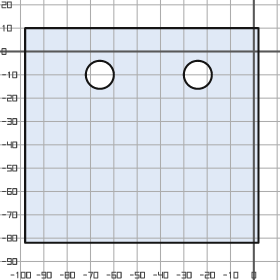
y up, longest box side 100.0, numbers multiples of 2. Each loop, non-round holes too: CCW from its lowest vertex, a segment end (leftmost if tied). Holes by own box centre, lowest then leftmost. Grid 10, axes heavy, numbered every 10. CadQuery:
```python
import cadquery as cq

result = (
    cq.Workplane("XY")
    .moveTo(-98.0, -82.0)
    .lineTo(2.0, -82.0)
    .lineTo(2.0, 10.0)
    .lineTo(-98.0, 10.0)
    .close()
    .moveTo(-66.0, -10.0)
    .circle(6.0)
    .moveTo(-24.0, -10.0)
    .circle(6.0)
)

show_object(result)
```